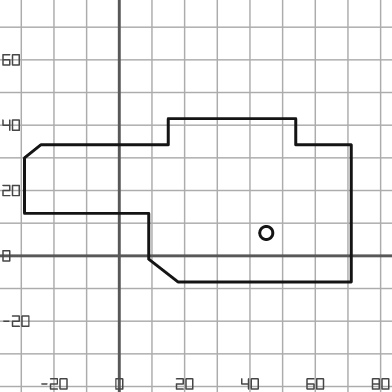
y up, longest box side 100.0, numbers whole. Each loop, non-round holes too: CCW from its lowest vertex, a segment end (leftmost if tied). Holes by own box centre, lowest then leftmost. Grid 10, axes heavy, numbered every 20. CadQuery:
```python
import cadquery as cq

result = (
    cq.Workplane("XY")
    .moveTo(18.0, -8.0)
    .lineTo(71.0, -8.0)
    .lineTo(71.0, 34.0)
    .lineTo(54.0, 34.0)
    .lineTo(54.0, 42.0)
    .lineTo(15.0, 42.0)
    .lineTo(15.0, 34.0)
    .lineTo(-24.0, 34.0)
    .lineTo(-29.0, 30.0)
    .lineTo(-29.0, 13.0)
    .lineTo(9.0, 13.0)
    .lineTo(9.0, -1.0)
    .close()
    .moveTo(45.0, 7.0)
    .circle(2.0)
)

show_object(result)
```